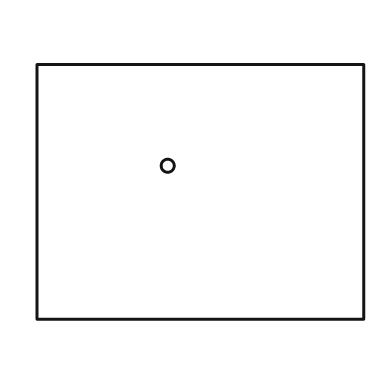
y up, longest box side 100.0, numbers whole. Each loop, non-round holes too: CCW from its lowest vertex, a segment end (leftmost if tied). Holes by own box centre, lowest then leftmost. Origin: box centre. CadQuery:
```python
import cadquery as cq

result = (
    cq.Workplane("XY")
    .moveTo(-50.0, -39.0)
    .lineTo(50.0, -39.0)
    .lineTo(50.0, 39.0)
    .lineTo(-50.0, 39.0)
    .close()
    .moveTo(-10.0, 8.0)
    .circle(2.0)
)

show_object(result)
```